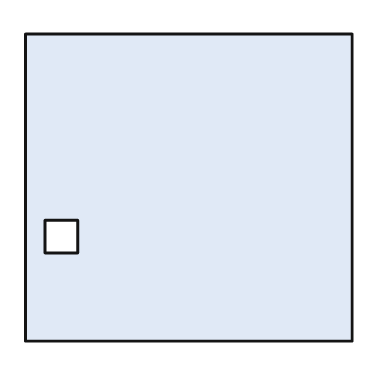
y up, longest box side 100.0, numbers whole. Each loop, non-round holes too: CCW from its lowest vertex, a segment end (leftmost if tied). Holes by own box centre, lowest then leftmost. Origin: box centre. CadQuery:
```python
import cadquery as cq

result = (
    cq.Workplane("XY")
    .moveTo(-50.0, -47.0)
    .lineTo(50.0, -47.0)
    .lineTo(50.0, 47.0)
    .lineTo(-50.0, 47.0)
    .close()
    .moveTo(-44.0, -20.0)
    .lineTo(-34.0, -20.0)
    .lineTo(-34.0, -10.0)
    .lineTo(-44.0, -10.0)
    .close()
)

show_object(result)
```